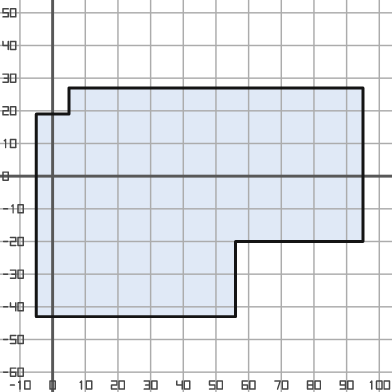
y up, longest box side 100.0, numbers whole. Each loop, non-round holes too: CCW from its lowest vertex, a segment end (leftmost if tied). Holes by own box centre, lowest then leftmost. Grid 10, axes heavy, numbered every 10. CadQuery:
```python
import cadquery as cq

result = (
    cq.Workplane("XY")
    .moveTo(-5.0, -43.0)
    .lineTo(56.0, -43.0)
    .lineTo(56.0, -20.0)
    .lineTo(95.0, -20.0)
    .lineTo(95.0, 27.0)
    .lineTo(5.0, 27.0)
    .lineTo(5.0, 19.0)
    .lineTo(-5.0, 19.0)
    .close()
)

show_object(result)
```